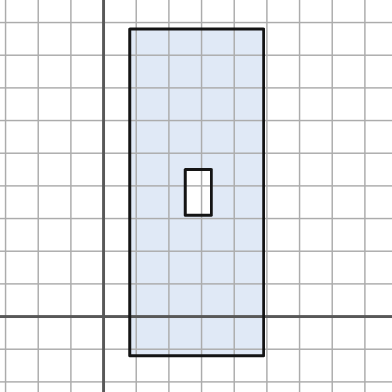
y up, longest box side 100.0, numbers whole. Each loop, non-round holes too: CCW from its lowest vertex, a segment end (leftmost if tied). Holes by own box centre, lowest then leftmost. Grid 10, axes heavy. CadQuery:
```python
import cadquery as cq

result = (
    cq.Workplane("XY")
    .moveTo(8.0, -12.0)
    .lineTo(49.0, -12.0)
    .lineTo(49.0, 88.0)
    .lineTo(8.0, 88.0)
    .close()
    .moveTo(25.0, 31.0)
    .lineTo(33.0, 31.0)
    .lineTo(33.0, 45.0)
    .lineTo(25.0, 45.0)
    .close()
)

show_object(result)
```